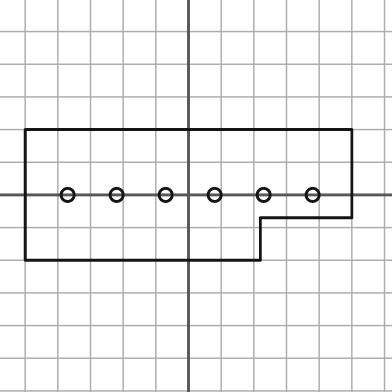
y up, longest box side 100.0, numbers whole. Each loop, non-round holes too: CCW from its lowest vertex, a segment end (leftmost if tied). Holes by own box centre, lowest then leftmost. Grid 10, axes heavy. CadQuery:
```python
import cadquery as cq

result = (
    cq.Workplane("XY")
    .moveTo(-50.0, -20.0)
    .lineTo(22.0, -20.0)
    .lineTo(22.0, -7.0)
    .lineTo(50.0, -7.0)
    .lineTo(50.0, 20.0)
    .lineTo(-50.0, 20.0)
    .close()
    .moveTo(-37.0, 0.0)
    .circle(2.0)
    .moveTo(-22.0, 0.0)
    .circle(2.0)
    .moveTo(-7.0, 0.0)
    .circle(2.0)
    .moveTo(8.0, 0.0)
    .circle(2.0)
    .moveTo(23.0, 0.0)
    .circle(2.0)
    .moveTo(38.0, 0.0)
    .circle(2.0)
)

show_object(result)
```